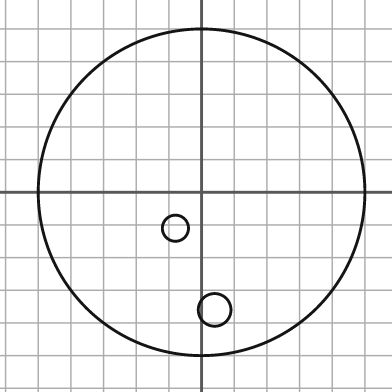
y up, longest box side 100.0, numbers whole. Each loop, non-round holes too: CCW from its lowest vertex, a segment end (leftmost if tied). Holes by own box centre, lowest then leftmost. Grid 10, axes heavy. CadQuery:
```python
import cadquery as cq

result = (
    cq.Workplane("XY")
    .moveTo(0.0, 0.0)
    .circle(50.0)
    .moveTo(4.0, -36.0)
    .circle(5.0)
    .moveTo(-8.0, -11.0)
    .circle(4.0)
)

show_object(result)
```